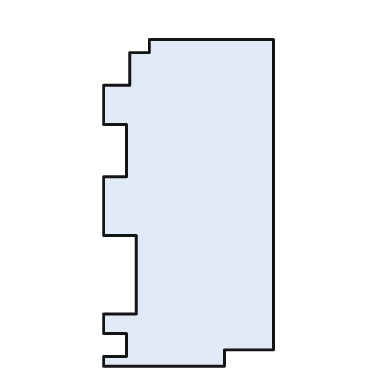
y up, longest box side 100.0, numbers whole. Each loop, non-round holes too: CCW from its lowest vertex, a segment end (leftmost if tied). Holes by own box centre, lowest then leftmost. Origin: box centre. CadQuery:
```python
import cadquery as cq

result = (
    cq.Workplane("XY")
    .moveTo(-26.0, -50.0)
    .lineTo(11.0, -50.0)
    .lineTo(11.0, -45.0)
    .lineTo(26.0, -45.0)
    .lineTo(26.0, 50.0)
    .lineTo(-12.0, 50.0)
    .lineTo(-12.0, 46.0)
    .lineTo(-18.0, 46.0)
    .lineTo(-18.0, 36.0)
    .lineTo(-26.0, 36.0)
    .lineTo(-26.0, 24.0)
    .lineTo(-19.0, 24.0)
    .lineTo(-19.0, 8.0)
    .lineTo(-26.0, 8.0)
    .lineTo(-26.0, -10.0)
    .lineTo(-16.0, -10.0)
    .lineTo(-16.0, -34.0)
    .lineTo(-26.0, -34.0)
    .lineTo(-26.0, -40.0)
    .lineTo(-19.0, -40.0)
    .lineTo(-19.0, -47.0)
    .lineTo(-26.0, -47.0)
    .close()
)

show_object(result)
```